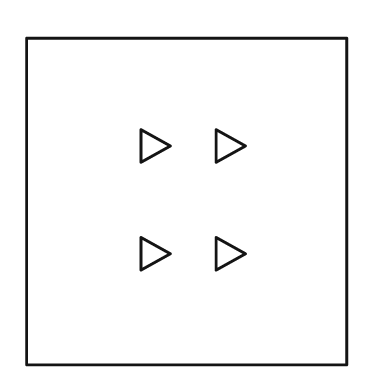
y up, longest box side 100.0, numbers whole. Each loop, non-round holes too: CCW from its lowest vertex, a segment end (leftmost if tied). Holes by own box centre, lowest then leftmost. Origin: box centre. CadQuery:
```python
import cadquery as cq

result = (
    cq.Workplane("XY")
    .moveTo(-49.0, -50.0)
    .lineTo(49.0, -50.0)
    .lineTo(49.0, 50.0)
    .lineTo(-49.0, 50.0)
    .close()
    .moveTo(-14.0, -21.0)
    .lineTo(-5.0, -16.0)
    .lineTo(-14.0, -11.0)
    .close()
    .moveTo(9.0, -21.0)
    .lineTo(18.0, -16.0)
    .lineTo(9.0, -11.0)
    .close()
    .moveTo(-14.0, 12.0)
    .lineTo(-5.0, 17.0)
    .lineTo(-14.0, 22.0)
    .close()
    .moveTo(9.0, 12.0)
    .lineTo(18.0, 17.0)
    .lineTo(9.0, 22.0)
    .close()
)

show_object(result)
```